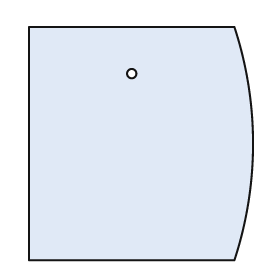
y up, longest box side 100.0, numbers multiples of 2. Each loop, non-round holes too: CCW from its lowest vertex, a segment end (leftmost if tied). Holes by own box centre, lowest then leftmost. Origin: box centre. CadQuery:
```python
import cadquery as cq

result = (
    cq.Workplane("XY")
    .moveTo(-48.0, -50.0)
    .lineTo(40.0, -50.0)
    .threePointArc((48.0, 0.0), (40.0, 50.0))
    .lineTo(-48.0, 50.0)
    .close()
    .moveTo(-4.0, 30.0)
    .circle(2.0)
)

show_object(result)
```